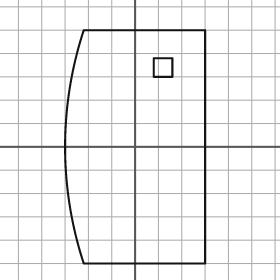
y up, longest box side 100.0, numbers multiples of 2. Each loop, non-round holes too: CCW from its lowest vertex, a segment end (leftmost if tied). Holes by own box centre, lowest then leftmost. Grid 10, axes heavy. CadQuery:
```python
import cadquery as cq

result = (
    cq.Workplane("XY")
    .moveTo(-22.0, -50.0)
    .lineTo(30.0, -50.0)
    .lineTo(30.0, 50.0)
    .lineTo(-22.0, 50.0)
    .threePointArc((-30.0, 0.0), (-22.0, -50.0))
    .close()
    .moveTo(8.0, 30.0)
    .lineTo(16.0, 30.0)
    .lineTo(16.0, 38.0)
    .lineTo(8.0, 38.0)
    .close()
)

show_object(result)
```